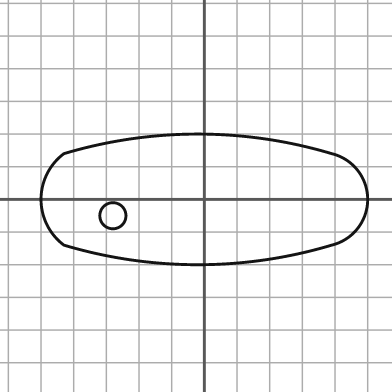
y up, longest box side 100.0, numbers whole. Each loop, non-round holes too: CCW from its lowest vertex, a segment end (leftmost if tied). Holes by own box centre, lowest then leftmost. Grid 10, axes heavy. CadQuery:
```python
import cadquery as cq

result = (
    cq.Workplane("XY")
    .moveTo(-43.0, -14.0)
    .threePointArc((-2.0, -20.0), (39.0, -14.0))
    .threePointArc((50.0, 0.0), (39.0, 14.0))
    .threePointArc((-2.0, 20.0), (-43.0, 14.0))
    .threePointArc((-50.0, 0.0), (-43.0, -14.0))
    .close()
    .moveTo(-28.0, -5.0)
    .circle(4.0)
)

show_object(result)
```